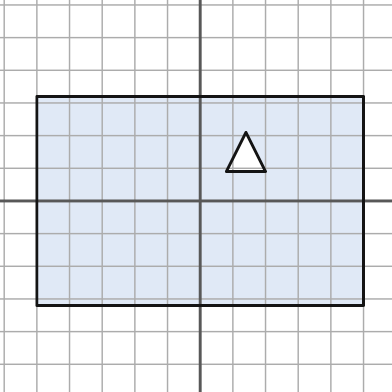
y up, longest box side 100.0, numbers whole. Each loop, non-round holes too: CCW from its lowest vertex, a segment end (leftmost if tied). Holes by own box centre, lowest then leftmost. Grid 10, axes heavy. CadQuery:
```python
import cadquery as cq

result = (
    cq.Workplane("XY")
    .moveTo(-50.0, -32.0)
    .lineTo(50.0, -32.0)
    .lineTo(50.0, 32.0)
    .lineTo(-50.0, 32.0)
    .close()
    .moveTo(8.0, 9.0)
    .lineTo(20.0, 9.0)
    .lineTo(14.0, 21.0)
    .close()
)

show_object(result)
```